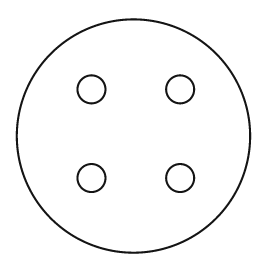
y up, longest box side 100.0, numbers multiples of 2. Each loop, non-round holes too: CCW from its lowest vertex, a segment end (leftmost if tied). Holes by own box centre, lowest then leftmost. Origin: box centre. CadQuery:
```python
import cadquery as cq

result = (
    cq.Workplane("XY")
    .moveTo(0.0, 0.0)
    .circle(50.0)
    .moveTo(-18.0, -18.0)
    .circle(6.0)
    .moveTo(20.0, -18.0)
    .circle(6.0)
    .moveTo(-18.0, 20.0)
    .circle(6.0)
    .moveTo(20.0, 20.0)
    .circle(6.0)
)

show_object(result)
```